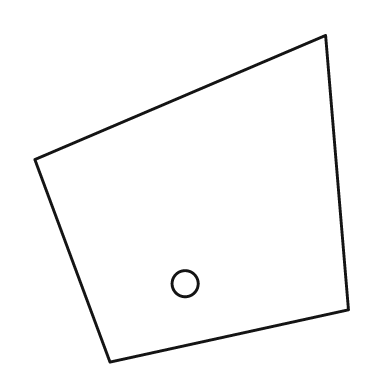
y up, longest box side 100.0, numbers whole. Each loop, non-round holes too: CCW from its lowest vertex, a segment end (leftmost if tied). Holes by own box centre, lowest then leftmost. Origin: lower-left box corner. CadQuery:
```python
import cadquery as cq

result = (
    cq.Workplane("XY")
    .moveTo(23.0, 0.0)
    .lineTo(96.0, 16.0)
    .lineTo(89.0, 100.0)
    .lineTo(0.0, 62.0)
    .close()
    .moveTo(46.0, 24.0)
    .circle(4.0)
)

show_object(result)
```